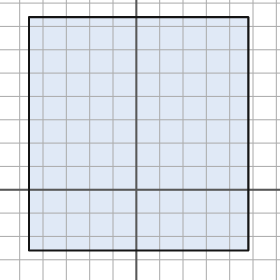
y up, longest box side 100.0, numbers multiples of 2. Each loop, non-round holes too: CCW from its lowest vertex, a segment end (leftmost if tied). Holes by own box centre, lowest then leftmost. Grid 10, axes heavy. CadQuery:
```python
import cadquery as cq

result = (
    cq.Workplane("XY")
    .moveTo(-46.0, -26.0)
    .lineTo(48.0, -26.0)
    .lineTo(48.0, 74.0)
    .lineTo(-46.0, 74.0)
    .close()
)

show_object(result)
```